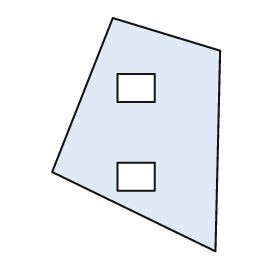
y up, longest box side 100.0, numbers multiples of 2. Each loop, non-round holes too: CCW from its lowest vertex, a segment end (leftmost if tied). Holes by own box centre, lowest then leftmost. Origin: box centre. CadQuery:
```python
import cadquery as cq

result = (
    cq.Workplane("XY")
    .moveTo(34.0, -50.0)
    .lineTo(36.0, 36.0)
    .lineTo(-10.0, 50.0)
    .lineTo(-36.0, -16.0)
    .close()
    .moveTo(-8.0, -24.0)
    .lineTo(8.0, -24.0)
    .lineTo(8.0, -12.0)
    .lineTo(-8.0, -12.0)
    .close()
    .moveTo(-8.0, 14.0)
    .lineTo(8.0, 14.0)
    .lineTo(8.0, 26.0)
    .lineTo(-8.0, 26.0)
    .close()
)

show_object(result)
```